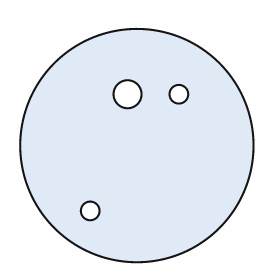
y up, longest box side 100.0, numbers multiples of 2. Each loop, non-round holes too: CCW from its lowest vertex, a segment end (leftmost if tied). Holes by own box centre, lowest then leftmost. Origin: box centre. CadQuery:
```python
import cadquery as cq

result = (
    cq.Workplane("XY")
    .moveTo(0.0, 0.0)
    .circle(50.0)
    .moveTo(-20.0, -28.0)
    .circle(4.0)
    .moveTo(-4.0, 22.0)
    .circle(6.0)
    .moveTo(18.0, 22.0)
    .circle(4.0)
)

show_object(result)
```